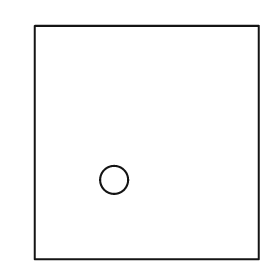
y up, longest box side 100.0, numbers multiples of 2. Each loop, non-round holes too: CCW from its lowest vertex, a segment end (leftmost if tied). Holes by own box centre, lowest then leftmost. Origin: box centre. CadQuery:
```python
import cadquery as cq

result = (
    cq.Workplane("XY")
    .moveTo(-48.0, -50.0)
    .lineTo(48.0, -50.0)
    .lineTo(48.0, 50.0)
    .lineTo(-48.0, 50.0)
    .close()
    .moveTo(-14.0, -16.0)
    .circle(6.0)
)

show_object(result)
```